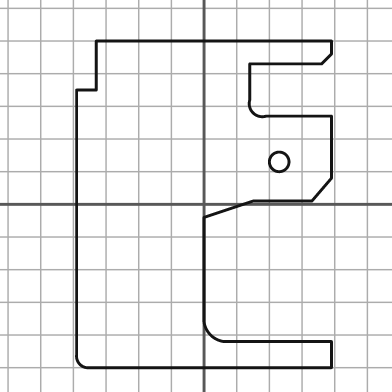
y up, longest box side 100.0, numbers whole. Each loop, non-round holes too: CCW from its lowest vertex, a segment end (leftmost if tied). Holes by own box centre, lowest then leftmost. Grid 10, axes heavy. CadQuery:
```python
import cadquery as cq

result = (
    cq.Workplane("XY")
    .moveTo(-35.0, -50.0)
    .lineTo(39.0, -50.0)
    .lineTo(39.0, -42.0)
    .lineTo(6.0, -42.0)
    .threePointArc((2.0, -40.0), (0.0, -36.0))
    .lineTo(0.0, -4.0)
    .lineTo(15.0, 1.0)
    .lineTo(33.0, 1.0)
    .lineTo(39.0, 8.0)
    .lineTo(39.0, 27.0)
    .lineTo(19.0, 27.0)
    .threePointArc((15.0, 28.0), (14.0, 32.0))
    .lineTo(14.0, 43.0)
    .lineTo(36.0, 43.0)
    .lineTo(39.0, 46.0)
    .lineTo(39.0, 50.0)
    .lineTo(-33.0, 50.0)
    .lineTo(-33.0, 35.0)
    .lineTo(-39.0, 35.0)
    .lineTo(-39.0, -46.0)
    .threePointArc((-38.0, -49.0), (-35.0, -50.0))
    .close()
    .moveTo(23.0, 13.0)
    .circle(3.0)
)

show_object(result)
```